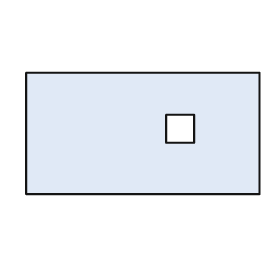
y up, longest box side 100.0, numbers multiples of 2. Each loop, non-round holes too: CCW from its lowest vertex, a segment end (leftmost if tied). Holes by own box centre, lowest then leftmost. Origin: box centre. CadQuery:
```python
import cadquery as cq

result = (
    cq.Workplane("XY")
    .moveTo(-50.0, -26.0)
    .lineTo(50.0, -26.0)
    .lineTo(50.0, 26.0)
    .lineTo(-50.0, 26.0)
    .close()
    .moveTo(10.0, -4.0)
    .lineTo(22.0, -4.0)
    .lineTo(22.0, 8.0)
    .lineTo(10.0, 8.0)
    .close()
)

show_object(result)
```